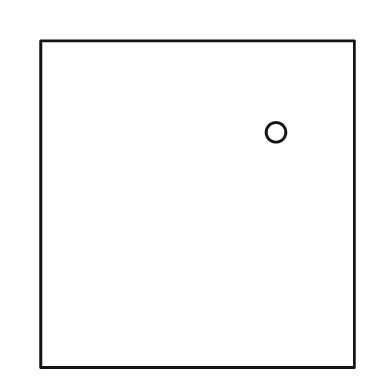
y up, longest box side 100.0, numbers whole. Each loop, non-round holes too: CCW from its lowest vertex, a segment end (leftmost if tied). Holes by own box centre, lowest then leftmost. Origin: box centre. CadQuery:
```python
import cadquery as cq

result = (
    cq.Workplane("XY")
    .moveTo(-48.0, -50.0)
    .lineTo(48.0, -50.0)
    .lineTo(48.0, 50.0)
    .lineTo(-48.0, 50.0)
    .close()
    .moveTo(24.0, 22.0)
    .circle(3.0)
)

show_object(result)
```